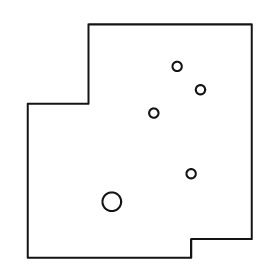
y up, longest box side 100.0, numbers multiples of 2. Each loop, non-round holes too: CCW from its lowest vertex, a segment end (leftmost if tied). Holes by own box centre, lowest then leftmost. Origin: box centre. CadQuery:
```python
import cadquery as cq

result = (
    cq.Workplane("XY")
    .moveTo(-48.0, -50.0)
    .lineTo(22.0, -50.0)
    .lineTo(22.0, -42.0)
    .lineTo(48.0, -42.0)
    .lineTo(48.0, 50.0)
    .lineTo(-22.0, 50.0)
    .lineTo(-22.0, 16.0)
    .lineTo(-48.0, 16.0)
    .close()
    .moveTo(-12.0, -26.0)
    .circle(4.0)
    .moveTo(22.0, -14.0)
    .circle(2.0)
    .moveTo(6.0, 12.0)
    .circle(2.0)
    .moveTo(26.0, 22.0)
    .circle(2.0)
    .moveTo(16.0, 32.0)
    .circle(2.0)
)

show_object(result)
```